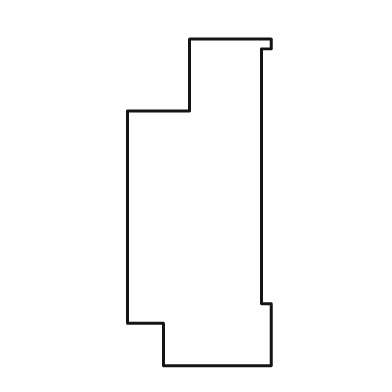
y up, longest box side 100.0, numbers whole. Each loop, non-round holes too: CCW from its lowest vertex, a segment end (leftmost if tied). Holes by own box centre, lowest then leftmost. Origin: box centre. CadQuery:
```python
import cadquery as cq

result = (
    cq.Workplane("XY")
    .moveTo(-11.0, -50.0)
    .lineTo(22.0, -50.0)
    .lineTo(22.0, -31.0)
    .lineTo(19.0, -31.0)
    .lineTo(19.0, 47.0)
    .lineTo(22.0, 47.0)
    .lineTo(22.0, 50.0)
    .lineTo(-3.0, 50.0)
    .lineTo(-3.0, 28.0)
    .lineTo(-22.0, 28.0)
    .lineTo(-22.0, -37.0)
    .lineTo(-11.0, -37.0)
    .close()
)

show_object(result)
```